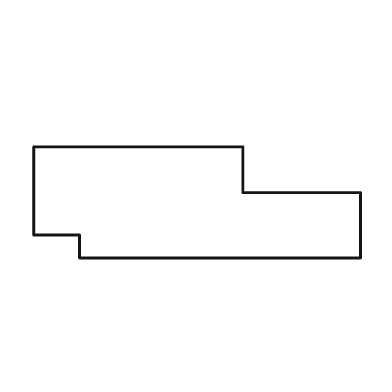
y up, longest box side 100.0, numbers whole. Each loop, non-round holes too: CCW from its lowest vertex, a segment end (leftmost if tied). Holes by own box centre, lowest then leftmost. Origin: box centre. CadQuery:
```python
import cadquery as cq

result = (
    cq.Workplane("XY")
    .moveTo(-36.0, -17.0)
    .lineTo(50.0, -17.0)
    .lineTo(50.0, 3.0)
    .lineTo(14.0, 3.0)
    .lineTo(14.0, 17.0)
    .lineTo(-50.0, 17.0)
    .lineTo(-50.0, -10.0)
    .lineTo(-36.0, -10.0)
    .close()
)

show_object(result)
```